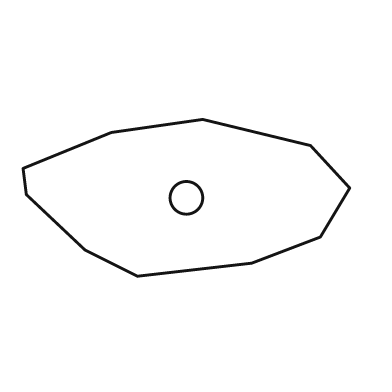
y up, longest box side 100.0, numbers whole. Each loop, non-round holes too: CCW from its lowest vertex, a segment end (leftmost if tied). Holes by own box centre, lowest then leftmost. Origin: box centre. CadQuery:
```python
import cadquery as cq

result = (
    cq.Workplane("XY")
    .moveTo(-15.0, -24.0)
    .lineTo(20.0, -20.0)
    .lineTo(41.0, -12.0)
    .lineTo(50.0, 3.0)
    .lineTo(38.0, 16.0)
    .lineTo(5.0, 24.0)
    .lineTo(-23.0, 20.0)
    .lineTo(-50.0, 9.0)
    .lineTo(-49.0, 1.0)
    .lineTo(-31.0, -16.0)
    .close()
    .moveTo(0.0, 0.0)
    .circle(5.0)
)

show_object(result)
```